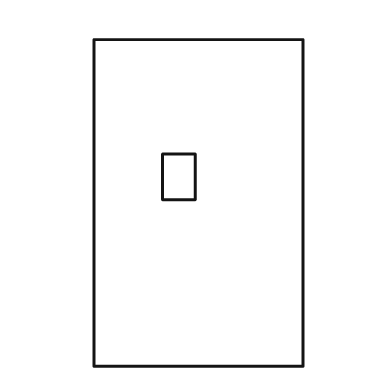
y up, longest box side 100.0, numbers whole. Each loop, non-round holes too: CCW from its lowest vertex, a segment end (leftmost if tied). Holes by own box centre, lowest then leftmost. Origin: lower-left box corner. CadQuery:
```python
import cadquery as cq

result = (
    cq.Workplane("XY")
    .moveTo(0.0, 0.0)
    .lineTo(64.0, 0.0)
    .lineTo(64.0, 100.0)
    .lineTo(0.0, 100.0)
    .close()
    .moveTo(21.0, 51.0)
    .lineTo(31.0, 51.0)
    .lineTo(31.0, 65.0)
    .lineTo(21.0, 65.0)
    .close()
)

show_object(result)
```